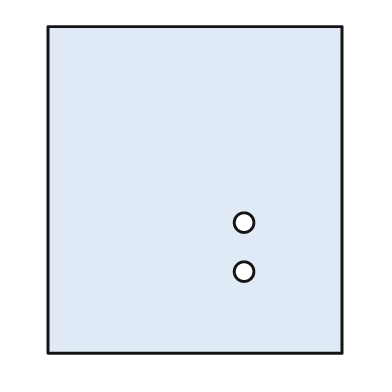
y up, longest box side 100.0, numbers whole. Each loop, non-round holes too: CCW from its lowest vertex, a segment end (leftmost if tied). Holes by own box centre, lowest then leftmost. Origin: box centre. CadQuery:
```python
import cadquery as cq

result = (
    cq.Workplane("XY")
    .moveTo(-45.0, -50.0)
    .lineTo(45.0, -50.0)
    .lineTo(45.0, 50.0)
    .lineTo(-45.0, 50.0)
    .close()
    .moveTo(15.0, -25.0)
    .circle(3.0)
    .moveTo(15.0, -10.0)
    .circle(3.0)
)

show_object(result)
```